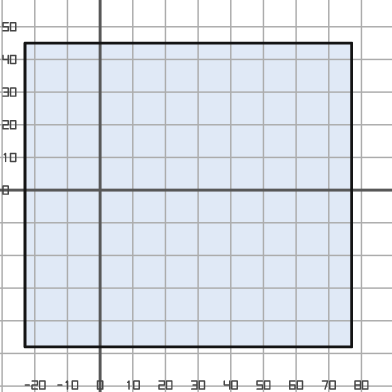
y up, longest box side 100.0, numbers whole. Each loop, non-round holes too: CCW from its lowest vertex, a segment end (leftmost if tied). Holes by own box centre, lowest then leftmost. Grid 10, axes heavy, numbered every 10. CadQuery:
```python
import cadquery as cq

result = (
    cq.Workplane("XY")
    .moveTo(-23.0, -48.0)
    .lineTo(77.0, -48.0)
    .lineTo(77.0, 45.0)
    .lineTo(-23.0, 45.0)
    .close()
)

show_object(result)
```